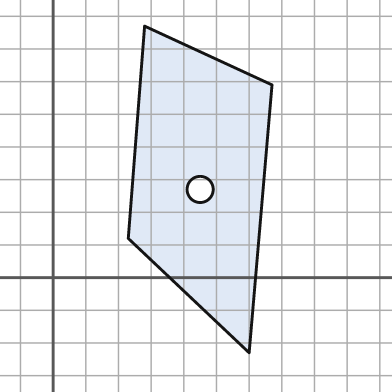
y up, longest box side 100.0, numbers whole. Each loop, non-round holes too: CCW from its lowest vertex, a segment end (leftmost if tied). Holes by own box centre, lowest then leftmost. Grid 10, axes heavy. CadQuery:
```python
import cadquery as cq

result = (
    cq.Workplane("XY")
    .moveTo(60.0, -23.0)
    .lineTo(67.0, 59.0)
    .lineTo(28.0, 77.0)
    .lineTo(23.0, 12.0)
    .close()
    .moveTo(45.0, 27.0)
    .circle(4.0)
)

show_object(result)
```